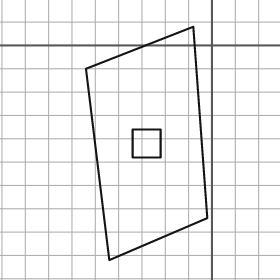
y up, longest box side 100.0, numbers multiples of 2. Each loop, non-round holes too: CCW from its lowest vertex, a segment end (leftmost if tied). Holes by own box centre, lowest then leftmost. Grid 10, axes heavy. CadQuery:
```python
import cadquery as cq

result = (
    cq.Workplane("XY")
    .moveTo(-44.0, -92.0)
    .lineTo(-2.0, -74.0)
    .lineTo(-8.0, 8.0)
    .lineTo(-54.0, -10.0)
    .close()
    .moveTo(-34.0, -48.0)
    .lineTo(-22.0, -48.0)
    .lineTo(-22.0, -36.0)
    .lineTo(-34.0, -36.0)
    .close()
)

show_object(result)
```